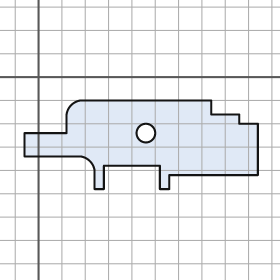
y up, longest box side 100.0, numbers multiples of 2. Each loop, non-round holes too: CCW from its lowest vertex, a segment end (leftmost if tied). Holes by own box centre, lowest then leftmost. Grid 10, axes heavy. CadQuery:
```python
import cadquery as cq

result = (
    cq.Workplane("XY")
    .moveTo(24.0, -48.0)
    .lineTo(28.0, -48.0)
    .lineTo(28.0, -38.0)
    .lineTo(52.0, -38.0)
    .lineTo(52.0, -48.0)
    .lineTo(56.0, -48.0)
    .lineTo(56.0, -42.0)
    .lineTo(94.0, -42.0)
    .lineTo(94.0, -20.0)
    .lineTo(86.0, -20.0)
    .lineTo(86.0, -16.0)
    .lineTo(74.0, -16.0)
    .lineTo(74.0, -10.0)
    .lineTo(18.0, -10.0)
    .threePointArc((14.0, -12.0), (12.0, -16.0))
    .lineTo(12.0, -24.0)
    .lineTo(-6.0, -24.0)
    .lineTo(-6.0, -34.0)
    .lineTo(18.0, -34.0)
    .threePointArc((22.0, -36.0), (24.0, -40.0))
    .close()
    .moveTo(46.0, -24.0)
    .circle(4.0)
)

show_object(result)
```